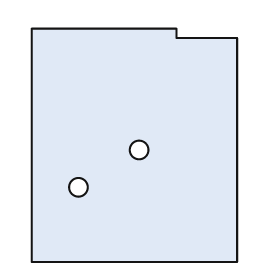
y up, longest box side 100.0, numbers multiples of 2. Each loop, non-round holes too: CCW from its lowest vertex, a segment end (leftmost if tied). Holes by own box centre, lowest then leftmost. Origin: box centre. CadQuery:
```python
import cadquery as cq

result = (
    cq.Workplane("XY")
    .moveTo(-44.0, -50.0)
    .lineTo(44.0, -50.0)
    .lineTo(44.0, 46.0)
    .lineTo(18.0, 46.0)
    .lineTo(18.0, 50.0)
    .lineTo(-44.0, 50.0)
    .close()
    .moveTo(-24.0, -18.0)
    .circle(4.0)
    .moveTo(2.0, -2.0)
    .circle(4.0)
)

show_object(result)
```